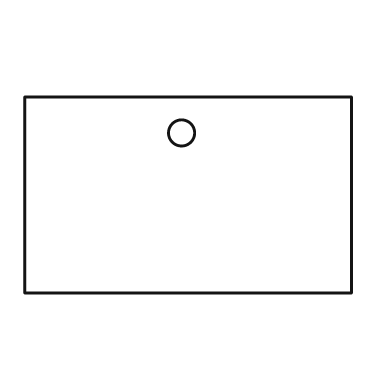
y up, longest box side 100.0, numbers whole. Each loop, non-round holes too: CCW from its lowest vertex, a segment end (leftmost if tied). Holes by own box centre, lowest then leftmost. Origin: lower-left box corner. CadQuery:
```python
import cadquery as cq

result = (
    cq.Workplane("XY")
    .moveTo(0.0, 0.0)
    .lineTo(100.0, 0.0)
    .lineTo(100.0, 60.0)
    .lineTo(0.0, 60.0)
    .close()
    .moveTo(48.0, 49.0)
    .circle(4.0)
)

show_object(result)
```